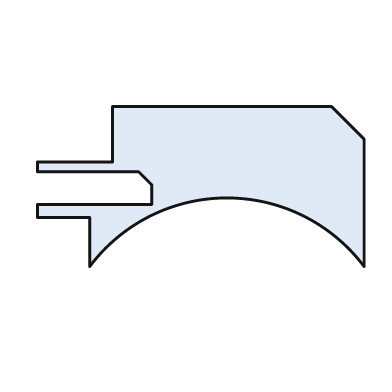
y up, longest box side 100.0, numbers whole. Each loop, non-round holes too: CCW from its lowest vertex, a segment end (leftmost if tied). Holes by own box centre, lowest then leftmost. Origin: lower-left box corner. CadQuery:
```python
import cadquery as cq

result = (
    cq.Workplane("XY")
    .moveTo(16.0, 0.0)
    .threePointArc((58.0, 21.0), (100.0, 0.0))
    .lineTo(100.0, 39.0)
    .lineTo(90.0, 49.0)
    .lineTo(23.0, 49.0)
    .lineTo(23.0, 32.0)
    .lineTo(0.0, 32.0)
    .lineTo(0.0, 29.0)
    .lineTo(31.0, 29.0)
    .lineTo(35.0, 25.0)
    .lineTo(35.0, 19.0)
    .lineTo(0.0, 19.0)
    .lineTo(0.0, 15.0)
    .lineTo(16.0, 15.0)
    .close()
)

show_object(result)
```